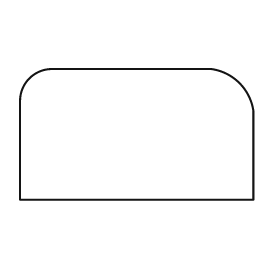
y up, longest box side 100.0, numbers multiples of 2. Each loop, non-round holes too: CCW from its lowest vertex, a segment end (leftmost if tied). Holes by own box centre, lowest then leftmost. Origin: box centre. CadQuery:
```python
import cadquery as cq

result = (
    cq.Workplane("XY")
    .moveTo(-50.0, -28.0)
    .lineTo(50.0, -28.0)
    .lineTo(50.0, 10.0)
    .threePointArc((44.0, 22.0), (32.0, 28.0))
    .lineTo(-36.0, 28.0)
    .threePointArc((-46.0, 24.0), (-50.0, 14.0))
    .close()
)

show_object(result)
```